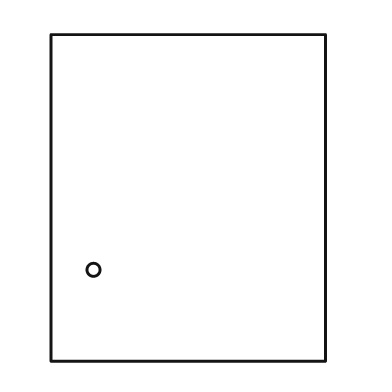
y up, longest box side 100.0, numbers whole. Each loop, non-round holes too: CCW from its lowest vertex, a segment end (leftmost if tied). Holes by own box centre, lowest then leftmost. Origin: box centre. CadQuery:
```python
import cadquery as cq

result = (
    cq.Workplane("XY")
    .moveTo(-42.0, -50.0)
    .lineTo(42.0, -50.0)
    .lineTo(42.0, 50.0)
    .lineTo(-42.0, 50.0)
    .close()
    .moveTo(-29.0, -22.0)
    .circle(2.0)
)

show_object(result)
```